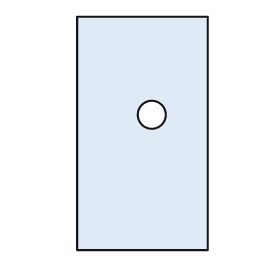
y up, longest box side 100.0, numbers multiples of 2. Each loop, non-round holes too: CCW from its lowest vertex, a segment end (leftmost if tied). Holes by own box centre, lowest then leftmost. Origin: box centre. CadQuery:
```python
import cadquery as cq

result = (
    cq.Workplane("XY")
    .moveTo(-28.0, -50.0)
    .lineTo(28.0, -50.0)
    .lineTo(28.0, 50.0)
    .lineTo(-28.0, 50.0)
    .close()
    .moveTo(4.0, 8.0)
    .circle(6.0)
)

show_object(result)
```